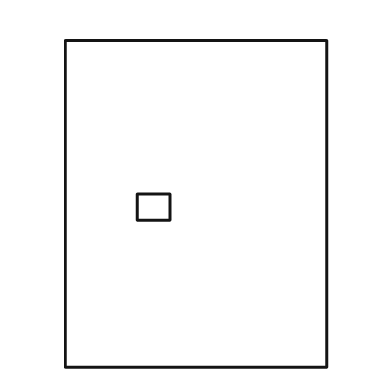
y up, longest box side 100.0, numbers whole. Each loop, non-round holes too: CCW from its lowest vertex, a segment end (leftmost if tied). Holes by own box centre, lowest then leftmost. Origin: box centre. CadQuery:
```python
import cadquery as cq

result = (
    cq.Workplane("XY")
    .moveTo(-40.0, -50.0)
    .lineTo(40.0, -50.0)
    .lineTo(40.0, 50.0)
    .lineTo(-40.0, 50.0)
    .close()
    .moveTo(-18.0, -5.0)
    .lineTo(-8.0, -5.0)
    .lineTo(-8.0, 3.0)
    .lineTo(-18.0, 3.0)
    .close()
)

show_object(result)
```